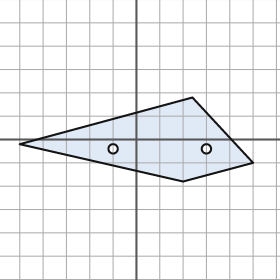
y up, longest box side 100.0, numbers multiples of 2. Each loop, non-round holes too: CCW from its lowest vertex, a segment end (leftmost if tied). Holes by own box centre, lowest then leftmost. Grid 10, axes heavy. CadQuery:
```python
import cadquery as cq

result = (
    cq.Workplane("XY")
    .moveTo(20.0, -18.0)
    .lineTo(50.0, -10.0)
    .lineTo(24.0, 18.0)
    .lineTo(-50.0, -2.0)
    .close()
    .moveTo(-10.0, -4.0)
    .circle(2.0)
    .moveTo(30.0, -4.0)
    .circle(2.0)
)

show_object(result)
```